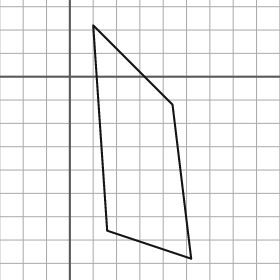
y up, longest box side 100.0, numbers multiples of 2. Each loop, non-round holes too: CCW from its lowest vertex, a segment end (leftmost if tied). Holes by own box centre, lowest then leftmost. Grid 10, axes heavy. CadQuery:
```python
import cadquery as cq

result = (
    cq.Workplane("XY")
    .moveTo(52.0, -78.0)
    .lineTo(44.0, -12.0)
    .lineTo(10.0, 22.0)
    .lineTo(16.0, -66.0)
    .close()
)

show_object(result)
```